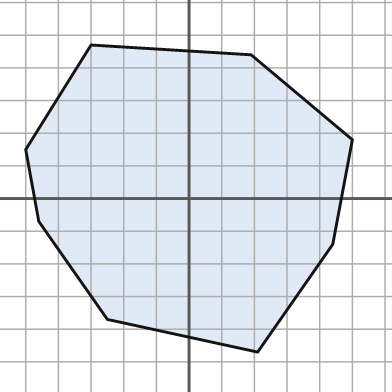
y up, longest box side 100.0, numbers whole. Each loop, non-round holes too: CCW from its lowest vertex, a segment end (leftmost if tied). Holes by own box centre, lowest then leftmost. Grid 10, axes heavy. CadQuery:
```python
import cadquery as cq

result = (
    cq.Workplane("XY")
    .moveTo(21.0, -47.0)
    .lineTo(44.0, -14.0)
    .lineTo(50.0, 18.0)
    .lineTo(19.0, 44.0)
    .lineTo(-30.0, 47.0)
    .lineTo(-50.0, 15.0)
    .lineTo(-46.0, -7.0)
    .lineTo(-25.0, -37.0)
    .close()
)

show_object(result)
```